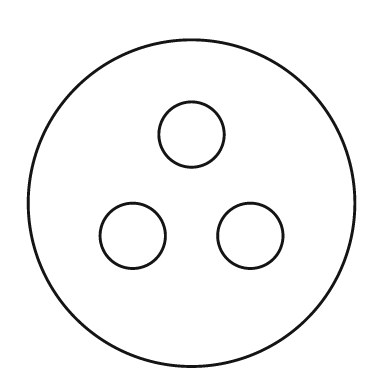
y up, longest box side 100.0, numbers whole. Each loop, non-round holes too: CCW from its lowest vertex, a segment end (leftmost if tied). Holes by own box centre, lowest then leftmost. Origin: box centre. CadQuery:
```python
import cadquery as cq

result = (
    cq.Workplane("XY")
    .moveTo(0.0, 0.0)
    .circle(50.0)
    .moveTo(-18.0, -10.0)
    .circle(10.0)
    .moveTo(18.0, -10.0)
    .circle(10.0)
    .moveTo(0.0, 21.0)
    .circle(10.0)
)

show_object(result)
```